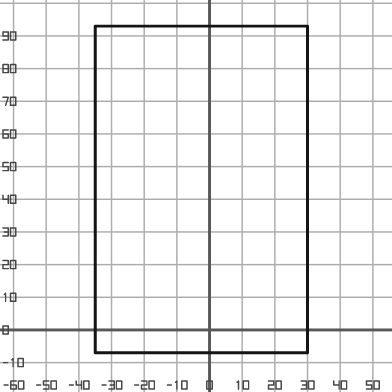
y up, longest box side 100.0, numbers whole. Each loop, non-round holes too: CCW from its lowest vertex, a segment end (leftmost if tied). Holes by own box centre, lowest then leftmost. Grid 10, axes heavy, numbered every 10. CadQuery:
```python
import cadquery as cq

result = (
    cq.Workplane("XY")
    .moveTo(-35.0, -7.0)
    .lineTo(30.0, -7.0)
    .lineTo(30.0, 93.0)
    .lineTo(-35.0, 93.0)
    .close()
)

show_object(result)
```